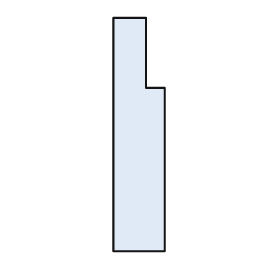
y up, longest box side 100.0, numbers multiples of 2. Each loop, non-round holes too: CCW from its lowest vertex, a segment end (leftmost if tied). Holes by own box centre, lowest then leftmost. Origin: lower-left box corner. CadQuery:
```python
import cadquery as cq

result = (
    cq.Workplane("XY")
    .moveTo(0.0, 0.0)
    .lineTo(22.0, 0.0)
    .lineTo(22.0, 70.0)
    .lineTo(14.0, 70.0)
    .lineTo(14.0, 100.0)
    .lineTo(0.0, 100.0)
    .close()
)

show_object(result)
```